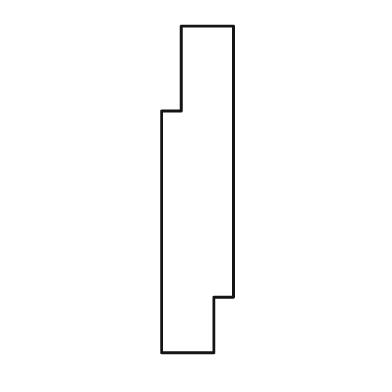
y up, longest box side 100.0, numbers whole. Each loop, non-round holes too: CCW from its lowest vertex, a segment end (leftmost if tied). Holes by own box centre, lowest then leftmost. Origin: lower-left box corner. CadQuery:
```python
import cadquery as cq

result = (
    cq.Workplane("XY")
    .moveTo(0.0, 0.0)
    .lineTo(16.0, 0.0)
    .lineTo(16.0, 17.0)
    .lineTo(22.0, 17.0)
    .lineTo(22.0, 100.0)
    .lineTo(6.0, 100.0)
    .lineTo(6.0, 74.0)
    .lineTo(0.0, 74.0)
    .close()
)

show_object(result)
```